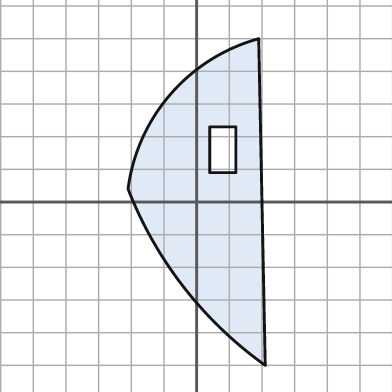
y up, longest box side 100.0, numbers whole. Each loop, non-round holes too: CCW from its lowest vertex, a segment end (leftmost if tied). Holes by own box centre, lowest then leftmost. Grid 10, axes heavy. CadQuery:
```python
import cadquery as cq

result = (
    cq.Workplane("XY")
    .moveTo(21.0, -50.0)
    .lineTo(19.0, 50.0)
    .threePointArc((-8.0, 33.0), (-21.0, 4.0))
    .threePointArc((-4.0, -26.0), (21.0, -50.0))
    .close()
    .moveTo(4.0, 9.0)
    .lineTo(12.0, 9.0)
    .lineTo(12.0, 23.0)
    .lineTo(4.0, 23.0)
    .close()
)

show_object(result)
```